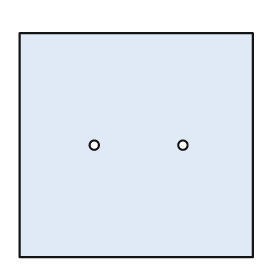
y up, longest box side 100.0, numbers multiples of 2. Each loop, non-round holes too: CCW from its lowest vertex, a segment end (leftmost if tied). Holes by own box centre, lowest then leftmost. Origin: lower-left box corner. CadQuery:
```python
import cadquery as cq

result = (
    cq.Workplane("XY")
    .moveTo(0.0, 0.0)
    .lineTo(100.0, 0.0)
    .lineTo(100.0, 96.0)
    .lineTo(0.0, 96.0)
    .close()
    .moveTo(32.0, 48.0)
    .circle(2.0)
    .moveTo(70.0, 48.0)
    .circle(2.0)
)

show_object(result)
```